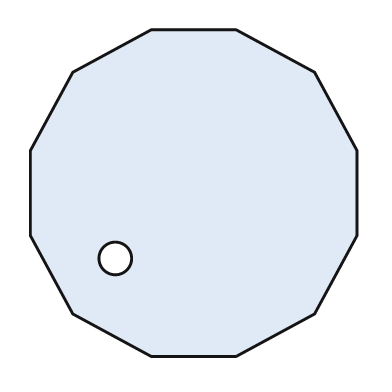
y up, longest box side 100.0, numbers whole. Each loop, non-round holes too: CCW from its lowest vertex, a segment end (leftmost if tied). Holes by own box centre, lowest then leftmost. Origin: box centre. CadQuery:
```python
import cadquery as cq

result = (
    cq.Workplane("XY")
    .moveTo(-13.0, -50.0)
    .lineTo(13.0, -50.0)
    .lineTo(37.0, -37.0)
    .lineTo(50.0, -13.0)
    .lineTo(50.0, 13.0)
    .lineTo(37.0, 37.0)
    .lineTo(13.0, 50.0)
    .lineTo(-13.0, 50.0)
    .lineTo(-37.0, 37.0)
    .lineTo(-50.0, 13.0)
    .lineTo(-50.0, -13.0)
    .lineTo(-37.0, -37.0)
    .close()
    .moveTo(-24.0, -20.0)
    .circle(5.0)
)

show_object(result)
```